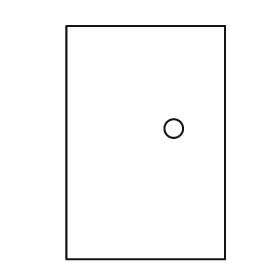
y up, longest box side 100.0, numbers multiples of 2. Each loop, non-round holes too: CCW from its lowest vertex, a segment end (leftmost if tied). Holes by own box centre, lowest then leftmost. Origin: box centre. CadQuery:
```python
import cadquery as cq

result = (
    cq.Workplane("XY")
    .moveTo(-34.0, -50.0)
    .lineTo(34.0, -50.0)
    .lineTo(34.0, 50.0)
    .lineTo(-34.0, 50.0)
    .close()
    .moveTo(12.0, 6.0)
    .circle(4.0)
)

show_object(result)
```